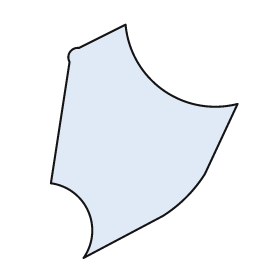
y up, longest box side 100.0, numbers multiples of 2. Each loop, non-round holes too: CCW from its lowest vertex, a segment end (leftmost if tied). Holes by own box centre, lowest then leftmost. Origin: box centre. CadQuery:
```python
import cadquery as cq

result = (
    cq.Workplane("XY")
    .moveTo(-26.0, -50.0)
    .lineTo(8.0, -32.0)
    .threePointArc((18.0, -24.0), (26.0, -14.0))
    .lineTo(40.0, 16.0)
    .threePointArc((8.0, 22.0), (-8.0, 50.0))
    .lineTo(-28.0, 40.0)
    .threePointArc((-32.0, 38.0), (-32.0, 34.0))
    .lineTo(-40.0, -18.0)
    .threePointArc((-24.0, -30.0), (-26.0, -50.0))
    .close()
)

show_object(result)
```